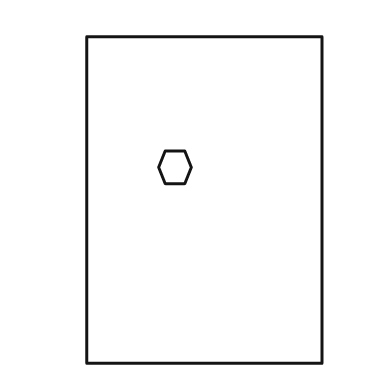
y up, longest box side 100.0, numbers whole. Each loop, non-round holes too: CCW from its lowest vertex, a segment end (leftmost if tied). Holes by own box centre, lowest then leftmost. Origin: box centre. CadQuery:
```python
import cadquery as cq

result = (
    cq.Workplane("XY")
    .moveTo(-36.0, -50.0)
    .lineTo(36.0, -50.0)
    .lineTo(36.0, 50.0)
    .lineTo(-36.0, 50.0)
    .close()
    .moveTo(-12.0, 5.0)
    .lineTo(-6.0, 5.0)
    .lineTo(-4.0, 10.0)
    .lineTo(-6.0, 15.0)
    .lineTo(-12.0, 15.0)
    .lineTo(-14.0, 10.0)
    .close()
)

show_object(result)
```